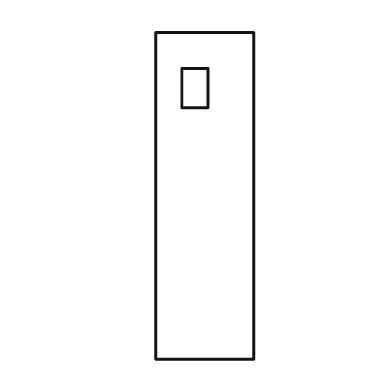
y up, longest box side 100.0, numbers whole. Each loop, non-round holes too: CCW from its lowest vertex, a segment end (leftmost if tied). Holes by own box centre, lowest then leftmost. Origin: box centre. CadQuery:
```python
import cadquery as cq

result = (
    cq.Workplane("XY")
    .moveTo(-15.0, -50.0)
    .lineTo(15.0, -50.0)
    .lineTo(15.0, 50.0)
    .lineTo(-15.0, 50.0)
    .close()
    .moveTo(-7.0, 27.0)
    .lineTo(1.0, 27.0)
    .lineTo(1.0, 39.0)
    .lineTo(-7.0, 39.0)
    .close()
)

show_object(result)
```